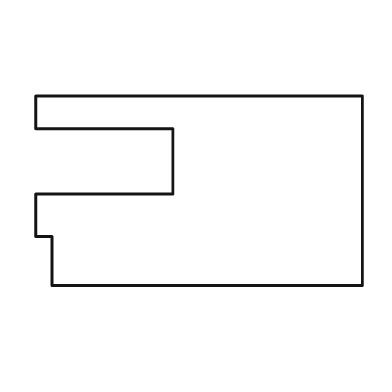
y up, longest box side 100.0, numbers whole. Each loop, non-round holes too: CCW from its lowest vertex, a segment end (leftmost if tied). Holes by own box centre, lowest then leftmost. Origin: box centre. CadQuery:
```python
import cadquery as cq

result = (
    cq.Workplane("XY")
    .moveTo(-45.0, -29.0)
    .lineTo(50.0, -29.0)
    .lineTo(50.0, 29.0)
    .lineTo(-50.0, 29.0)
    .lineTo(-50.0, 19.0)
    .lineTo(-8.0, 19.0)
    .lineTo(-8.0, -1.0)
    .lineTo(-50.0, -1.0)
    .lineTo(-50.0, -14.0)
    .lineTo(-45.0, -14.0)
    .close()
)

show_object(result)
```